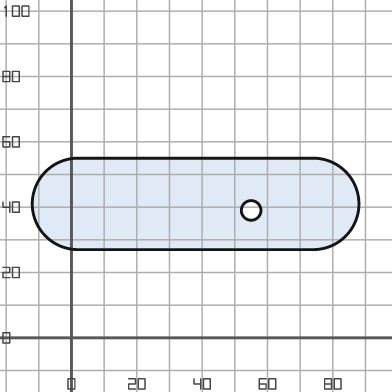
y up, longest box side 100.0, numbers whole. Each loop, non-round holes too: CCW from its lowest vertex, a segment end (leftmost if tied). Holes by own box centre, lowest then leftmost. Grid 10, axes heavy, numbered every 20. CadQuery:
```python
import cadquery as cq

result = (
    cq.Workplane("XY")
    .moveTo(2.0, 27.0)
    .lineTo(74.0, 27.0)
    .threePointArc((88.0, 41.0), (74.0, 55.0))
    .lineTo(2.0, 55.0)
    .threePointArc((-12.0, 41.0), (2.0, 27.0))
    .close()
    .moveTo(55.0, 39.0)
    .circle(3.0)
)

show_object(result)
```